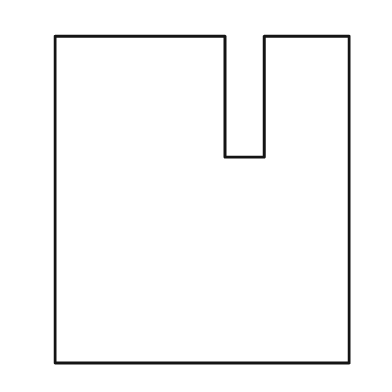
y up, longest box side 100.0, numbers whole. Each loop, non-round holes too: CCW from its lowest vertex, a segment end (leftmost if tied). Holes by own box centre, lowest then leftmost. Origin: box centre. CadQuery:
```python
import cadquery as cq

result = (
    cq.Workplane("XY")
    .moveTo(-45.0, -50.0)
    .lineTo(45.0, -50.0)
    .lineTo(45.0, 50.0)
    .lineTo(19.0, 50.0)
    .lineTo(19.0, 13.0)
    .lineTo(7.0, 13.0)
    .lineTo(7.0, 50.0)
    .lineTo(-45.0, 50.0)
    .close()
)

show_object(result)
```